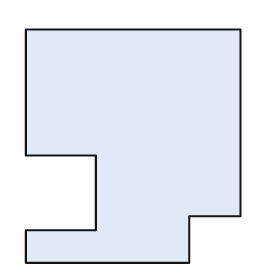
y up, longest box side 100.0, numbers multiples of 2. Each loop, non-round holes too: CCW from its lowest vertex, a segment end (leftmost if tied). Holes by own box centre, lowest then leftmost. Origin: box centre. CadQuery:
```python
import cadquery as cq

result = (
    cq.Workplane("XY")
    .moveTo(-46.0, -50.0)
    .lineTo(24.0, -50.0)
    .lineTo(24.0, -30.0)
    .lineTo(46.0, -30.0)
    .lineTo(46.0, 50.0)
    .lineTo(-46.0, 50.0)
    .lineTo(-46.0, -4.0)
    .lineTo(-16.0, -4.0)
    .lineTo(-16.0, -36.0)
    .lineTo(-46.0, -36.0)
    .close()
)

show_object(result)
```